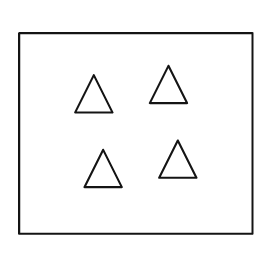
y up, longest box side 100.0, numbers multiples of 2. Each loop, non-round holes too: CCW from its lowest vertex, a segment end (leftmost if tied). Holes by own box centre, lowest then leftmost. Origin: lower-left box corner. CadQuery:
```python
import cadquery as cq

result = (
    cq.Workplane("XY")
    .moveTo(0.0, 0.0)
    .lineTo(100.0, 0.0)
    .lineTo(100.0, 86.0)
    .lineTo(0.0, 86.0)
    .close()
    .moveTo(28.0, 20.0)
    .lineTo(44.0, 20.0)
    .lineTo(36.0, 36.0)
    .close()
    .moveTo(60.0, 24.0)
    .lineTo(76.0, 24.0)
    .lineTo(68.0, 40.0)
    .close()
    .moveTo(24.0, 52.0)
    .lineTo(40.0, 52.0)
    .lineTo(32.0, 68.0)
    .close()
    .moveTo(56.0, 56.0)
    .lineTo(72.0, 56.0)
    .lineTo(64.0, 72.0)
    .close()
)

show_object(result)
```